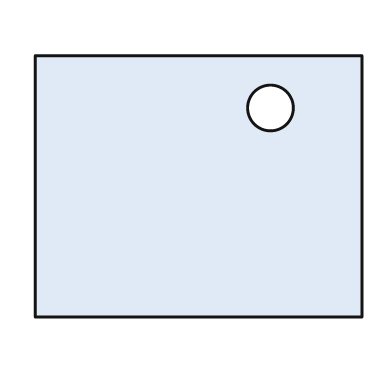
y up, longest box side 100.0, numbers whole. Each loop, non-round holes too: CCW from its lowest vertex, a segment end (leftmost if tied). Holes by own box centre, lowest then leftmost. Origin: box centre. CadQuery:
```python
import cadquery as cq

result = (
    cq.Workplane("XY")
    .moveTo(-50.0, -40.0)
    .lineTo(50.0, -40.0)
    .lineTo(50.0, 40.0)
    .lineTo(-50.0, 40.0)
    .close()
    .moveTo(22.0, 24.0)
    .circle(7.0)
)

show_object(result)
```